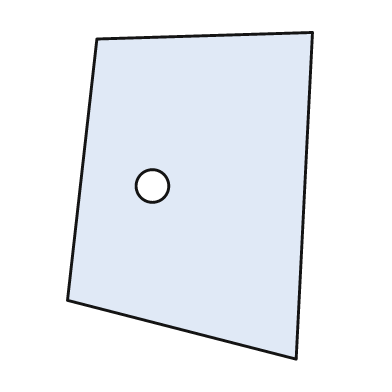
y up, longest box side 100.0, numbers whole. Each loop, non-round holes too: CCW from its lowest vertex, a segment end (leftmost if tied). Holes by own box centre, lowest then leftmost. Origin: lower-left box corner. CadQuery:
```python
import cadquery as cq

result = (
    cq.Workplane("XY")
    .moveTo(70.0, 0.0)
    .lineTo(75.0, 100.0)
    .lineTo(9.0, 98.0)
    .lineTo(0.0, 18.0)
    .close()
    .moveTo(26.0, 53.0)
    .circle(5.0)
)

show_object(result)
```